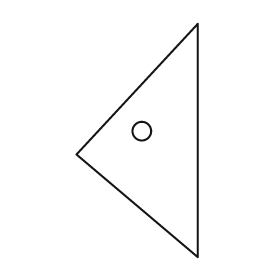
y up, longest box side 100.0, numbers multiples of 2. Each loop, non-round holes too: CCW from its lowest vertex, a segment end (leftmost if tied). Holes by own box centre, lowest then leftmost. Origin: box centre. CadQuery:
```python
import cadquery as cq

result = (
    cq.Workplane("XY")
    .moveTo(26.0, -50.0)
    .lineTo(26.0, 50.0)
    .lineTo(-26.0, -6.0)
    .close()
    .moveTo(2.0, 4.0)
    .circle(4.0)
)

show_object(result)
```